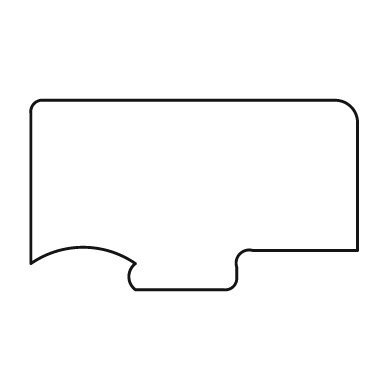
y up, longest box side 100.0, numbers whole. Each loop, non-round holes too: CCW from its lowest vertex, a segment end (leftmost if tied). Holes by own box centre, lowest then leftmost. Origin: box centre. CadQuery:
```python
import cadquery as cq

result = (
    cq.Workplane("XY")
    .moveTo(-18.0, -29.0)
    .lineTo(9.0, -29.0)
    .threePointArc((12.0, -28.0), (13.0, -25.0))
    .lineTo(13.0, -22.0)
    .threePointArc((14.0, -18.0), (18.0, -17.0))
    .lineTo(50.0, -17.0)
    .lineTo(50.0, 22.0)
    .threePointArc((48.0, 27.0), (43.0, 29.0))
    .lineTo(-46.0, 29.0)
    .threePointArc((-49.0, 28.0), (-50.0, 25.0))
    .lineTo(-50.0, -21.0)
    .threePointArc((-34.0, -16.0), (-18.0, -21.0))
    .threePointArc((-20.0, -25.0), (-18.0, -29.0))
    .close()
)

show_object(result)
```